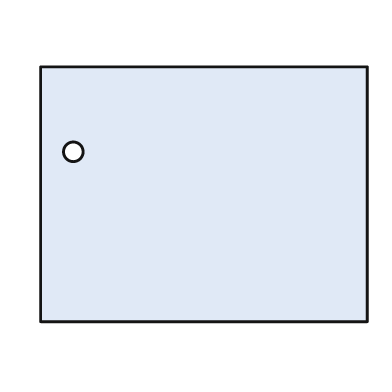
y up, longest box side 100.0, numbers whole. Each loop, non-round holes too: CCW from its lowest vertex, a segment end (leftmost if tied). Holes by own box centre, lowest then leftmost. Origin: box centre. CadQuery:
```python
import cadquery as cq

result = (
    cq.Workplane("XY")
    .moveTo(-50.0, -39.0)
    .lineTo(50.0, -39.0)
    .lineTo(50.0, 39.0)
    .lineTo(-50.0, 39.0)
    .close()
    .moveTo(-40.0, 13.0)
    .circle(3.0)
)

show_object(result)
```